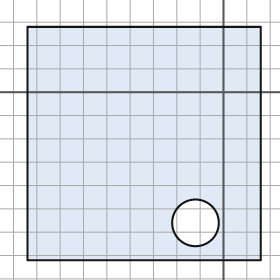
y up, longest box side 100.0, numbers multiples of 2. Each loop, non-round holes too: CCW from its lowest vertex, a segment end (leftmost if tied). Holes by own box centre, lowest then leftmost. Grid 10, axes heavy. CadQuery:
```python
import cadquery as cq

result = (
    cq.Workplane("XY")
    .moveTo(-84.0, -72.0)
    .lineTo(16.0, -72.0)
    .lineTo(16.0, 28.0)
    .lineTo(-84.0, 28.0)
    .close()
    .moveTo(-12.0, -56.0)
    .circle(10.0)
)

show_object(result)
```